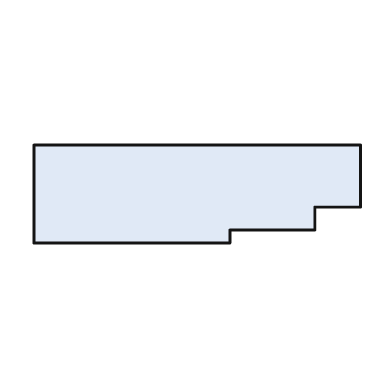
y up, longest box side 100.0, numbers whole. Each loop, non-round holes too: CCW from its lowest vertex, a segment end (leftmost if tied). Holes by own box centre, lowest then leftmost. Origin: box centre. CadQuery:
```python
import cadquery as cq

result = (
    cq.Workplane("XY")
    .moveTo(-50.0, -15.0)
    .lineTo(10.0, -15.0)
    .lineTo(10.0, -11.0)
    .lineTo(36.0, -11.0)
    .lineTo(36.0, -4.0)
    .lineTo(50.0, -4.0)
    .lineTo(50.0, 15.0)
    .lineTo(-50.0, 15.0)
    .close()
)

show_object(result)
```